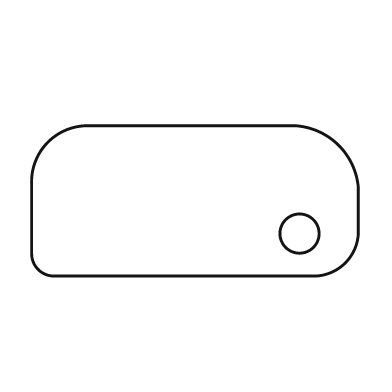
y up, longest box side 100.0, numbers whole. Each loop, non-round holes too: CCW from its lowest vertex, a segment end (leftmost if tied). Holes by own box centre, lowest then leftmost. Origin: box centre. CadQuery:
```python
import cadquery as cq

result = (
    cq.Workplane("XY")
    .moveTo(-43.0, -23.0)
    .lineTo(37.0, -23.0)
    .threePointArc((46.0, -19.0), (50.0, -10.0))
    .lineTo(50.0, 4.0)
    .threePointArc((44.0, 17.0), (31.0, 23.0))
    .lineTo(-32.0, 23.0)
    .threePointArc((-45.0, 18.0), (-50.0, 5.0))
    .lineTo(-50.0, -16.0)
    .threePointArc((-48.0, -21.0), (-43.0, -23.0))
    .close()
    .moveTo(32.0, -10.0)
    .circle(6.0)
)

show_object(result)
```